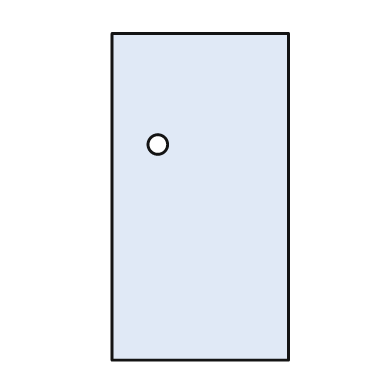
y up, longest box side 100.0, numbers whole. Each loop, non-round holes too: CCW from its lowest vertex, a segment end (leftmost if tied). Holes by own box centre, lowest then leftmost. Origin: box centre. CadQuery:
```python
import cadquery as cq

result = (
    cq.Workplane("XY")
    .moveTo(-27.0, -50.0)
    .lineTo(27.0, -50.0)
    .lineTo(27.0, 50.0)
    .lineTo(-27.0, 50.0)
    .close()
    .moveTo(-13.0, 16.0)
    .circle(3.0)
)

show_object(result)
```